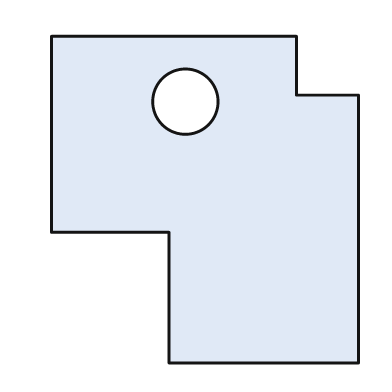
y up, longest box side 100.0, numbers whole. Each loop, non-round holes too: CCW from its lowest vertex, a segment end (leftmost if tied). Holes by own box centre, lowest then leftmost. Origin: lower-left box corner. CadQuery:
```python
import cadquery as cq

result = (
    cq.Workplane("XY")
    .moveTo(36.0, 0.0)
    .lineTo(94.0, 0.0)
    .lineTo(94.0, 82.0)
    .lineTo(75.0, 82.0)
    .lineTo(75.0, 100.0)
    .lineTo(0.0, 100.0)
    .lineTo(0.0, 40.0)
    .lineTo(36.0, 40.0)
    .close()
    .moveTo(41.0, 80.0)
    .circle(10.0)
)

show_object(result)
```